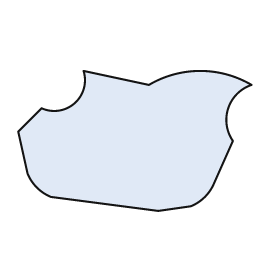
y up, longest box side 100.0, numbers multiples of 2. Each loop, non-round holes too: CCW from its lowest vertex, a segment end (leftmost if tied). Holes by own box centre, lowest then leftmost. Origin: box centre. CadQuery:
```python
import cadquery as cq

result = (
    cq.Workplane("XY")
    .moveTo(10.0, -30.0)
    .lineTo(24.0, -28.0)
    .threePointArc((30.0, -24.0), (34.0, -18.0))
    .lineTo(42.0, 0.0)
    .threePointArc((40.0, 14.0), (50.0, 24.0))
    .threePointArc((28.0, 30.0), (6.0, 24.0))
    .lineTo(-22.0, 30.0)
    .threePointArc((-26.0, 16.0), (-40.0, 14.0))
    .lineTo(-50.0, 4.0)
    .lineTo(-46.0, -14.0)
    .threePointArc((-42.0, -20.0), (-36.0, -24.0))
    .close()
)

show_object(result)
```